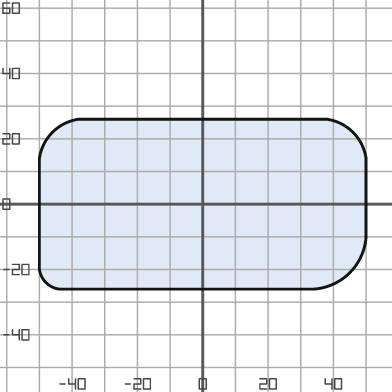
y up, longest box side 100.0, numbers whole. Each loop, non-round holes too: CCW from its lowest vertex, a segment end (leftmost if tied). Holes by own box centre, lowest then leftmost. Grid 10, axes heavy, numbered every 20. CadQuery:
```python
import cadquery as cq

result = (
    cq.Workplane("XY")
    .moveTo(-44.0, -26.0)
    .lineTo(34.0, -26.0)
    .threePointArc((45.0, -21.0), (50.0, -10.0))
    .lineTo(50.0, 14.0)
    .threePointArc((46.0, 22.0), (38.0, 26.0))
    .lineTo(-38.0, 26.0)
    .threePointArc((-46.0, 22.0), (-50.0, 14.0))
    .lineTo(-50.0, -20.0)
    .threePointArc((-48.0, -24.0), (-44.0, -26.0))
    .close()
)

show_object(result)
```